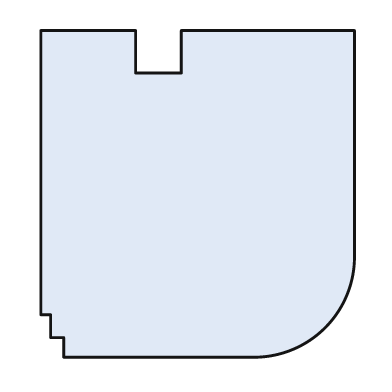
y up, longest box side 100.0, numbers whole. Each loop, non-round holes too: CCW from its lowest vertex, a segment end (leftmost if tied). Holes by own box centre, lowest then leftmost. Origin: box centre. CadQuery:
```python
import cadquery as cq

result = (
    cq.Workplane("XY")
    .moveTo(-41.0, -50.0)
    .lineTo(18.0, -50.0)
    .threePointArc((39.0, -41.0), (48.0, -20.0))
    .lineTo(48.0, 50.0)
    .lineTo(-5.0, 50.0)
    .lineTo(-5.0, 37.0)
    .lineTo(-19.0, 37.0)
    .lineTo(-19.0, 50.0)
    .lineTo(-48.0, 50.0)
    .lineTo(-48.0, -37.0)
    .lineTo(-45.0, -37.0)
    .lineTo(-45.0, -44.0)
    .lineTo(-41.0, -44.0)
    .close()
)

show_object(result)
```